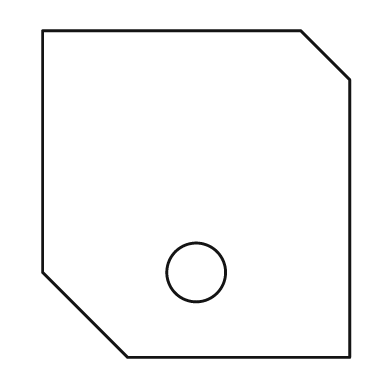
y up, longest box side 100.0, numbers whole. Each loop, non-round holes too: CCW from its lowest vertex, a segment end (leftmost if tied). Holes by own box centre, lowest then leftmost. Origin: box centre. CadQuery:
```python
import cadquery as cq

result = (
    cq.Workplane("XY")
    .moveTo(-21.0, -50.0)
    .lineTo(47.0, -50.0)
    .lineTo(47.0, 35.0)
    .lineTo(32.0, 50.0)
    .lineTo(-47.0, 50.0)
    .lineTo(-47.0, -24.0)
    .close()
    .moveTo(0.0, -24.0)
    .circle(9.0)
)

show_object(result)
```